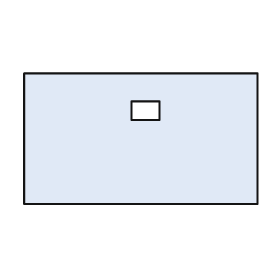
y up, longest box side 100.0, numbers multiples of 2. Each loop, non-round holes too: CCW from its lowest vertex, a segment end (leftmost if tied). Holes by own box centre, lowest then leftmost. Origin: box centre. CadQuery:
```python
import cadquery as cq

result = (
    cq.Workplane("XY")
    .moveTo(-50.0, -28.0)
    .lineTo(50.0, -28.0)
    .lineTo(50.0, 28.0)
    .lineTo(-50.0, 28.0)
    .close()
    .moveTo(-4.0, 8.0)
    .lineTo(8.0, 8.0)
    .lineTo(8.0, 16.0)
    .lineTo(-4.0, 16.0)
    .close()
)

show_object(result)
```